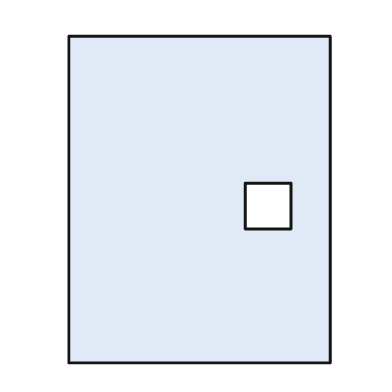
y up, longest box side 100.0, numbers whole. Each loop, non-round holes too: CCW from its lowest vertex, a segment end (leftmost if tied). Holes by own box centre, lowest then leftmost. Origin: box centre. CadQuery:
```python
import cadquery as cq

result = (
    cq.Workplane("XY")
    .moveTo(-40.0, -50.0)
    .lineTo(40.0, -50.0)
    .lineTo(40.0, 50.0)
    .lineTo(-40.0, 50.0)
    .close()
    .moveTo(14.0, -9.0)
    .lineTo(28.0, -9.0)
    .lineTo(28.0, 5.0)
    .lineTo(14.0, 5.0)
    .close()
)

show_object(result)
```